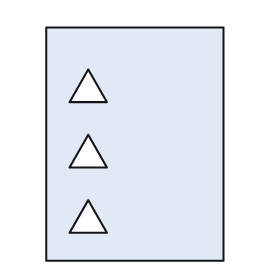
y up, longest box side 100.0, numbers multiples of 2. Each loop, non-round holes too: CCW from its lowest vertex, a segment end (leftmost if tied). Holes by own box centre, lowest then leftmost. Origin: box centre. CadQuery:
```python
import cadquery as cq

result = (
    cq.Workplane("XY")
    .moveTo(-38.0, -50.0)
    .lineTo(38.0, -50.0)
    .lineTo(38.0, 50.0)
    .lineTo(-38.0, 50.0)
    .close()
    .moveTo(-28.0, -38.0)
    .lineTo(-12.0, -38.0)
    .lineTo(-20.0, -24.0)
    .close()
    .moveTo(-28.0, -10.0)
    .lineTo(-12.0, -10.0)
    .lineTo(-20.0, 4.0)
    .close()
    .moveTo(-28.0, 18.0)
    .lineTo(-12.0, 18.0)
    .lineTo(-20.0, 32.0)
    .close()
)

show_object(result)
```